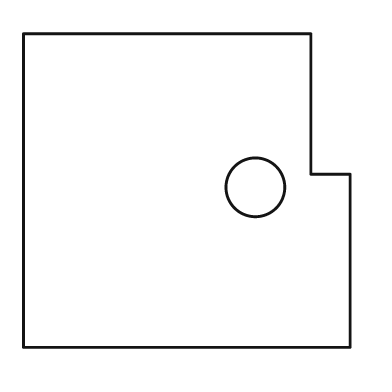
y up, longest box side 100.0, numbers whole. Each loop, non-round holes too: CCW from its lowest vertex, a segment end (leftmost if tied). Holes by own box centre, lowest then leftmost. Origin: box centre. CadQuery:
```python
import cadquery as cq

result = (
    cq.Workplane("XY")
    .moveTo(-50.0, -48.0)
    .lineTo(50.0, -48.0)
    .lineTo(50.0, 5.0)
    .lineTo(38.0, 5.0)
    .lineTo(38.0, 48.0)
    .lineTo(-50.0, 48.0)
    .close()
    .moveTo(21.0, 1.0)
    .circle(9.0)
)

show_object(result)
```